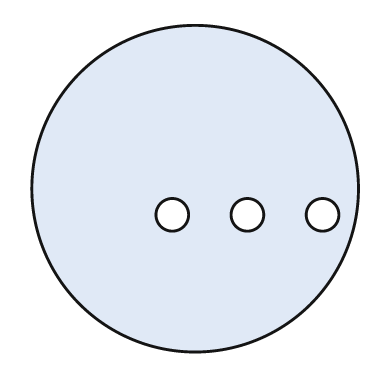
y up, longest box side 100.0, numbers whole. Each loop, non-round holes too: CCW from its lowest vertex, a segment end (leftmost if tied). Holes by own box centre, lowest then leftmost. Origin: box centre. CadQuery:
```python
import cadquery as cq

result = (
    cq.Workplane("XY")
    .moveTo(0.0, 0.0)
    .circle(50.0)
    .moveTo(-7.0, -8.0)
    .circle(5.0)
    .moveTo(16.0, -8.0)
    .circle(5.0)
    .moveTo(39.0, -8.0)
    .circle(5.0)
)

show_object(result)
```